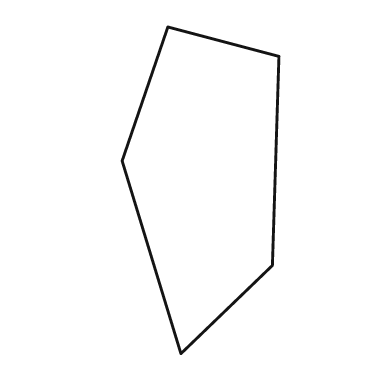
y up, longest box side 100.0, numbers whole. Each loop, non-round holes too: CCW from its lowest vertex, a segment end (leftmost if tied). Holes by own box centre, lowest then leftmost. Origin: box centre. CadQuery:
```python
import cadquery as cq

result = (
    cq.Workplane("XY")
    .moveTo(-6.0, -50.0)
    .lineTo(22.0, -23.0)
    .lineTo(24.0, 41.0)
    .lineTo(-10.0, 50.0)
    .lineTo(-24.0, 9.0)
    .close()
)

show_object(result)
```